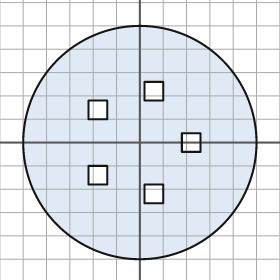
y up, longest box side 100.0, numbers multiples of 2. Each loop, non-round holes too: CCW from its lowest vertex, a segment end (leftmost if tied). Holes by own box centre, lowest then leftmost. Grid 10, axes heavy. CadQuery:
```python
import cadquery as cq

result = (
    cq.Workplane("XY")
    .moveTo(0.0, 0.0)
    .circle(50.0)
    .moveTo(2.0, -26.0)
    .lineTo(10.0, -26.0)
    .lineTo(10.0, -18.0)
    .lineTo(2.0, -18.0)
    .close()
    .moveTo(-22.0, -18.0)
    .lineTo(-14.0, -18.0)
    .lineTo(-14.0, -10.0)
    .lineTo(-22.0, -10.0)
    .close()
    .moveTo(18.0, -4.0)
    .lineTo(26.0, -4.0)
    .lineTo(26.0, 4.0)
    .lineTo(18.0, 4.0)
    .close()
    .moveTo(-22.0, 10.0)
    .lineTo(-14.0, 10.0)
    .lineTo(-14.0, 18.0)
    .lineTo(-22.0, 18.0)
    .close()
    .moveTo(2.0, 18.0)
    .lineTo(10.0, 18.0)
    .lineTo(10.0, 26.0)
    .lineTo(2.0, 26.0)
    .close()
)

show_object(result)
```